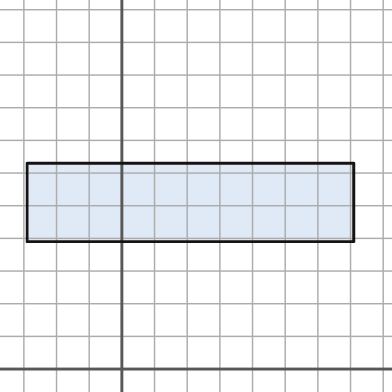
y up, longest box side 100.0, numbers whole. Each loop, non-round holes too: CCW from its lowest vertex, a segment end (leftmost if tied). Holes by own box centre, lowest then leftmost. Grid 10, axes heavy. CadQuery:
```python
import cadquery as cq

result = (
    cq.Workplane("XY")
    .moveTo(-29.0, 39.0)
    .lineTo(71.0, 39.0)
    .lineTo(71.0, 63.0)
    .lineTo(-29.0, 63.0)
    .close()
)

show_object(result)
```